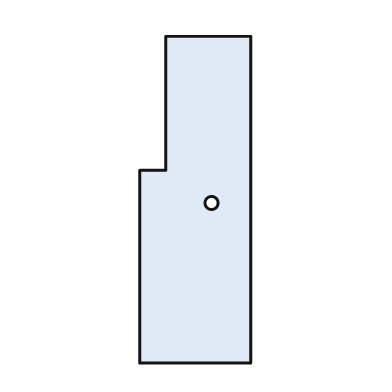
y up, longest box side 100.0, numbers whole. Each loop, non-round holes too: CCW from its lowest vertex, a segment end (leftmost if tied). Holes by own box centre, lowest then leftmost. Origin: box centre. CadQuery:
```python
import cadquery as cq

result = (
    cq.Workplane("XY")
    .moveTo(-17.0, -50.0)
    .lineTo(17.0, -50.0)
    .lineTo(17.0, 50.0)
    .lineTo(-9.0, 50.0)
    .lineTo(-9.0, 9.0)
    .lineTo(-17.0, 9.0)
    .close()
    .moveTo(5.0, -1.0)
    .circle(2.0)
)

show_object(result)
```